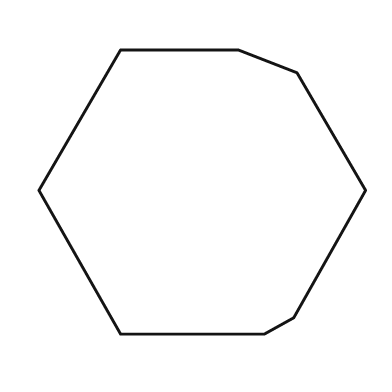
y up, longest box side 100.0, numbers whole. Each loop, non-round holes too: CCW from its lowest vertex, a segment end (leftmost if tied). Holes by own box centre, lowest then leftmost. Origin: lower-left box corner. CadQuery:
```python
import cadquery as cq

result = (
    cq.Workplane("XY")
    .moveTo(25.0, 0.0)
    .lineTo(69.0, 0.0)
    .lineTo(78.0, 5.0)
    .lineTo(100.0, 44.0)
    .lineTo(79.0, 80.0)
    .lineTo(61.0, 87.0)
    .lineTo(25.0, 87.0)
    .lineTo(0.0, 44.0)
    .close()
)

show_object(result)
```